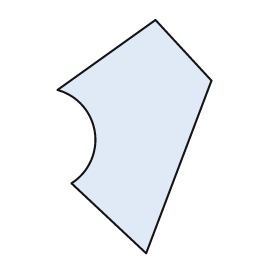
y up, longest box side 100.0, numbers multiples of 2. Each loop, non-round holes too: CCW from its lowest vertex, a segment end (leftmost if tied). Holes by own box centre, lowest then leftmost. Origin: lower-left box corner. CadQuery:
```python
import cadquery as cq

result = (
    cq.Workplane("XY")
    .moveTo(38.0, 0.0)
    .lineTo(66.0, 74.0)
    .lineTo(42.0, 100.0)
    .lineTo(0.0, 70.0)
    .threePointArc((16.0, 52.0), (6.0, 30.0))
    .close()
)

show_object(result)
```